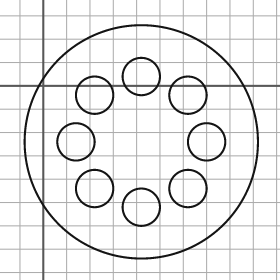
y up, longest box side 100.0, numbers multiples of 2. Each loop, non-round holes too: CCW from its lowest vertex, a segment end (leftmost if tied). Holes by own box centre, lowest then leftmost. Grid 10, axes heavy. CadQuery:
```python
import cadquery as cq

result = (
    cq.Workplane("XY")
    .moveTo(42.0, -24.0)
    .circle(50.0)
    .moveTo(42.0, -52.0)
    .circle(8.0)
    .moveTo(22.0, -44.0)
    .circle(8.0)
    .moveTo(62.0, -44.0)
    .circle(8.0)
    .moveTo(14.0, -24.0)
    .circle(8.0)
    .moveTo(70.0, -24.0)
    .circle(8.0)
    .moveTo(22.0, -4.0)
    .circle(8.0)
    .moveTo(62.0, -4.0)
    .circle(8.0)
    .moveTo(42.0, 4.0)
    .circle(8.0)
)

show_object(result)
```